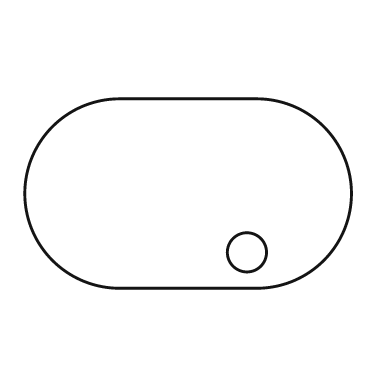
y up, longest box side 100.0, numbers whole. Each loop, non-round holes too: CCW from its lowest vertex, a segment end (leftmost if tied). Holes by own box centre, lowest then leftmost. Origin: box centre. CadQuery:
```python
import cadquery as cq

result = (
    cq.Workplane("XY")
    .moveTo(-21.0, -29.0)
    .lineTo(21.0, -29.0)
    .threePointArc((50.0, 0.0), (21.0, 29.0))
    .lineTo(-21.0, 29.0)
    .threePointArc((-50.0, 0.0), (-21.0, -29.0))
    .close()
    .moveTo(18.0, -18.0)
    .circle(6.0)
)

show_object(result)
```